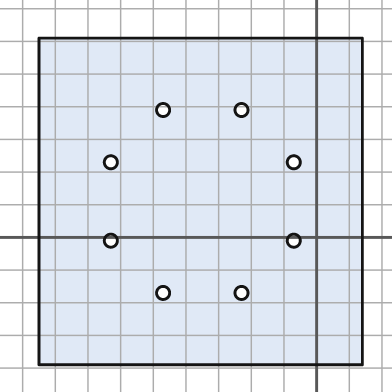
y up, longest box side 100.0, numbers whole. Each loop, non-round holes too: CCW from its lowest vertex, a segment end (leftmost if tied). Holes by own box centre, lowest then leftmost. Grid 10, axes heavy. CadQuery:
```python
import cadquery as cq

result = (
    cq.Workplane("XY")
    .moveTo(-85.0, -39.0)
    .lineTo(14.0, -39.0)
    .lineTo(14.0, 61.0)
    .lineTo(-85.0, 61.0)
    .close()
    .moveTo(-47.0, -17.0)
    .circle(2.0)
    .moveTo(-23.0, -17.0)
    .circle(2.0)
    .moveTo(-63.0, -1.0)
    .circle(2.0)
    .moveTo(-7.0, -1.0)
    .circle(2.0)
    .moveTo(-63.0, 23.0)
    .circle(2.0)
    .moveTo(-7.0, 23.0)
    .circle(2.0)
    .moveTo(-47.0, 39.0)
    .circle(2.0)
    .moveTo(-23.0, 39.0)
    .circle(2.0)
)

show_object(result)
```